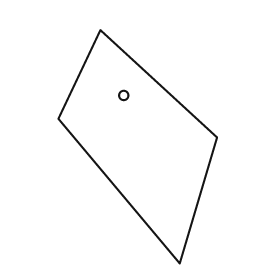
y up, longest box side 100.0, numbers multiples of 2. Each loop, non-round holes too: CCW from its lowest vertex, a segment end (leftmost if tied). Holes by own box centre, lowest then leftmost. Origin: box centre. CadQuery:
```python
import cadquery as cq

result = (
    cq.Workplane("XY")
    .moveTo(18.0, -50.0)
    .lineTo(34.0, 4.0)
    .lineTo(-16.0, 50.0)
    .lineTo(-34.0, 12.0)
    .close()
    .moveTo(-6.0, 22.0)
    .circle(2.0)
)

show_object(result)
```